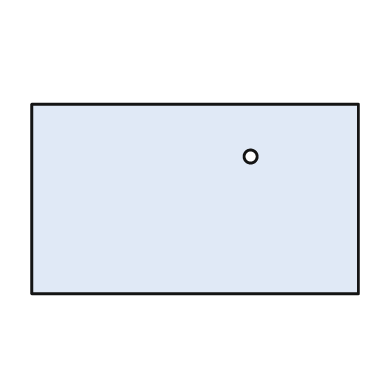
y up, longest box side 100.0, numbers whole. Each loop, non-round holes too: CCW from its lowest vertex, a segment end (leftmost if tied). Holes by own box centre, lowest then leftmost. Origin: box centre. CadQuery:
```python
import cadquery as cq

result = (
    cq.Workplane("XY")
    .moveTo(-50.0, -29.0)
    .lineTo(50.0, -29.0)
    .lineTo(50.0, 29.0)
    .lineTo(-50.0, 29.0)
    .close()
    .moveTo(17.0, 13.0)
    .circle(2.0)
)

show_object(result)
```